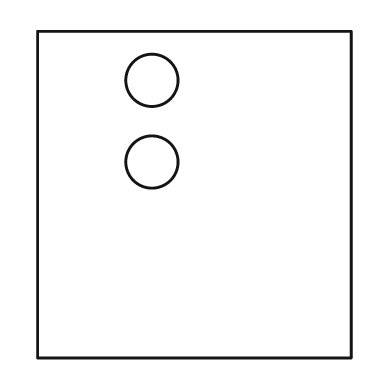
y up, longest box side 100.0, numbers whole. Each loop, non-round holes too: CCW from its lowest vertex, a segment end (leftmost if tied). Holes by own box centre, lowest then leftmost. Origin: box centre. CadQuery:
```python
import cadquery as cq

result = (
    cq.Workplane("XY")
    .moveTo(-48.0, -50.0)
    .lineTo(48.0, -50.0)
    .lineTo(48.0, 50.0)
    .lineTo(-48.0, 50.0)
    .close()
    .moveTo(-13.0, 10.0)
    .circle(8.0)
    .moveTo(-13.0, 35.0)
    .circle(8.0)
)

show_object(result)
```